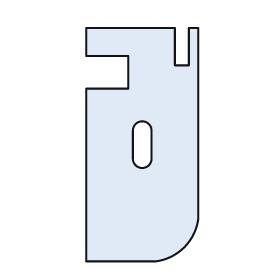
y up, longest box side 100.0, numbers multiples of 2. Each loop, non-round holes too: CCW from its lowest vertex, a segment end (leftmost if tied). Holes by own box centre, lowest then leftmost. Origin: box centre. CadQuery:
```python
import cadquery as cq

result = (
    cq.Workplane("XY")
    .moveTo(-24.0, -50.0)
    .lineTo(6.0, -50.0)
    .threePointArc((18.0, -44.0), (24.0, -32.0))
    .lineTo(24.0, 50.0)
    .lineTo(20.0, 50.0)
    .lineTo(20.0, 34.0)
    .lineTo(14.0, 34.0)
    .lineTo(14.0, 50.0)
    .lineTo(-24.0, 50.0)
    .lineTo(-24.0, 38.0)
    .lineTo(-6.0, 38.0)
    .lineTo(-6.0, 24.0)
    .lineTo(-24.0, 24.0)
    .close()
    .moveTo(-4.0, -6.0)
    .threePointArc((0.0, -10.0), (4.0, -6.0))
    .lineTo(4.0, 6.0)
    .threePointArc((0.0, 10.0), (-4.0, 6.0))
    .close()
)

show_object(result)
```